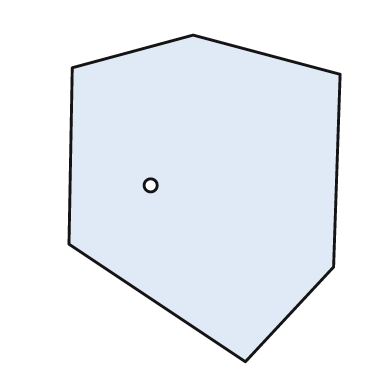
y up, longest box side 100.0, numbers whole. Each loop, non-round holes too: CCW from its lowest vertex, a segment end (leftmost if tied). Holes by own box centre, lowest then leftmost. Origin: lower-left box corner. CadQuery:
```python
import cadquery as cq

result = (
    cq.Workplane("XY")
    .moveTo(54.0, 0.0)
    .lineTo(81.0, 29.0)
    .lineTo(83.0, 88.0)
    .lineTo(38.0, 100.0)
    .lineTo(1.0, 90.0)
    .lineTo(0.0, 36.0)
    .close()
    .moveTo(25.0, 54.0)
    .circle(2.0)
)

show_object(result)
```